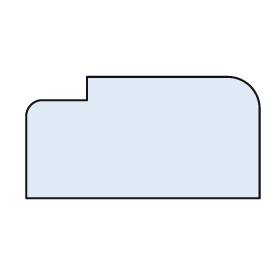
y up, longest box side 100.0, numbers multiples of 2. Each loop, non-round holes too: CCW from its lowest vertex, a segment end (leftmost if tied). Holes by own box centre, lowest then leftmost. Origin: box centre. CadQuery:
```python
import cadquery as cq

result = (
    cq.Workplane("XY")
    .moveTo(-50.0, -26.0)
    .lineTo(50.0, -26.0)
    .lineTo(50.0, 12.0)
    .threePointArc((46.0, 22.0), (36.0, 26.0))
    .lineTo(-24.0, 26.0)
    .lineTo(-24.0, 16.0)
    .lineTo(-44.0, 16.0)
    .threePointArc((-48.0, 14.0), (-50.0, 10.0))
    .close()
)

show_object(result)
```